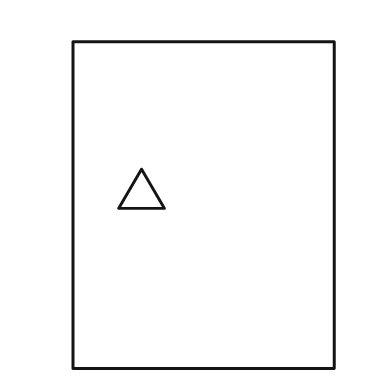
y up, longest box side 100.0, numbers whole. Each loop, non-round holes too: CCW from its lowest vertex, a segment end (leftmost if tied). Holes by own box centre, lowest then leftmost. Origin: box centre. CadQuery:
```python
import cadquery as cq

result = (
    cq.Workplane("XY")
    .moveTo(-40.0, -50.0)
    .lineTo(40.0, -50.0)
    .lineTo(40.0, 50.0)
    .lineTo(-40.0, 50.0)
    .close()
    .moveTo(-26.0, -1.0)
    .lineTo(-12.0, -1.0)
    .lineTo(-19.0, 11.0)
    .close()
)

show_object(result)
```